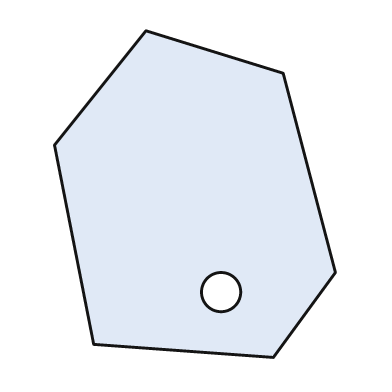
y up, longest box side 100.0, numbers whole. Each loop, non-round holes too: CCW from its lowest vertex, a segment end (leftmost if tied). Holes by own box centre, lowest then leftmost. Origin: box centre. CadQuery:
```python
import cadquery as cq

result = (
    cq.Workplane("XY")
    .moveTo(24.0, -50.0)
    .lineTo(43.0, -24.0)
    .lineTo(27.0, 37.0)
    .lineTo(-15.0, 50.0)
    .lineTo(-43.0, 15.0)
    .lineTo(-31.0, -46.0)
    .close()
    .moveTo(8.0, -30.0)
    .circle(6.0)
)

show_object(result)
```